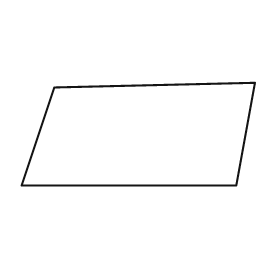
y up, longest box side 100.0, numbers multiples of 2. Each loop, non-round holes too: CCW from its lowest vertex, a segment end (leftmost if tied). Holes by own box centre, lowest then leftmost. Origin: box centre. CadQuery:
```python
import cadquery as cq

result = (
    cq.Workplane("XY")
    .moveTo(-50.0, -22.0)
    .lineTo(42.0, -22.0)
    .lineTo(50.0, 22.0)
    .lineTo(-36.0, 20.0)
    .close()
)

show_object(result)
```